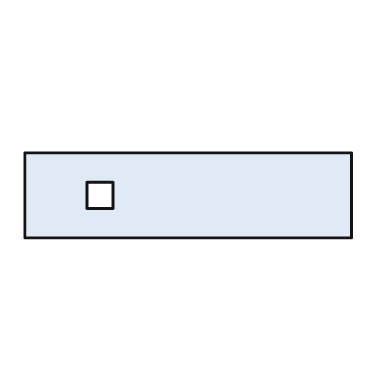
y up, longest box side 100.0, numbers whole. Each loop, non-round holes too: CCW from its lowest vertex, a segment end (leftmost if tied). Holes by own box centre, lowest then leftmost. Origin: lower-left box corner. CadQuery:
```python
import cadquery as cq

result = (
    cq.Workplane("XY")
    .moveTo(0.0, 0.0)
    .lineTo(100.0, 0.0)
    .lineTo(100.0, 26.0)
    .lineTo(0.0, 26.0)
    .close()
    .moveTo(19.0, 9.0)
    .lineTo(27.0, 9.0)
    .lineTo(27.0, 17.0)
    .lineTo(19.0, 17.0)
    .close()
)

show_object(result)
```